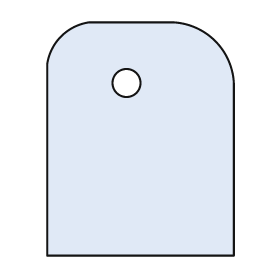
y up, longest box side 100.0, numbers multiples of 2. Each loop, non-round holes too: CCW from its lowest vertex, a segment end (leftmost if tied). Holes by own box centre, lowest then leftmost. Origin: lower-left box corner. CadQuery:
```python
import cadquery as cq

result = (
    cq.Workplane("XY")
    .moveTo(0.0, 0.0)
    .lineTo(80.0, 0.0)
    .lineTo(80.0, 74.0)
    .threePointArc((72.0, 92.0), (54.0, 100.0))
    .lineTo(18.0, 100.0)
    .threePointArc((6.0, 94.0), (0.0, 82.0))
    .close()
    .moveTo(34.0, 74.0)
    .circle(6.0)
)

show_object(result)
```